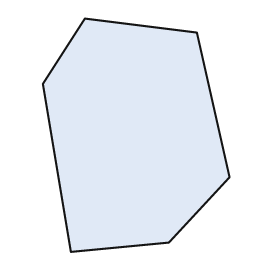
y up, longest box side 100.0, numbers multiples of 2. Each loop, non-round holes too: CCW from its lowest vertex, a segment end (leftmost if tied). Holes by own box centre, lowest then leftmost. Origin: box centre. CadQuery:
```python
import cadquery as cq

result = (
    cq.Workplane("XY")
    .moveTo(-28.0, -50.0)
    .lineTo(14.0, -46.0)
    .lineTo(40.0, -18.0)
    .lineTo(26.0, 44.0)
    .lineTo(-22.0, 50.0)
    .lineTo(-40.0, 22.0)
    .close()
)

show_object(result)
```